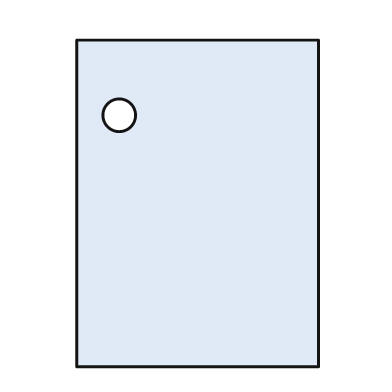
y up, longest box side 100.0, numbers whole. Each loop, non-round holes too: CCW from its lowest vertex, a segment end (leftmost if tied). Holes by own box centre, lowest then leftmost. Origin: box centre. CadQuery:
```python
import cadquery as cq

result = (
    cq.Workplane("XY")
    .moveTo(-37.0, -50.0)
    .lineTo(37.0, -50.0)
    .lineTo(37.0, 50.0)
    .lineTo(-37.0, 50.0)
    .close()
    .moveTo(-24.0, 27.0)
    .circle(5.0)
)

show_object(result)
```